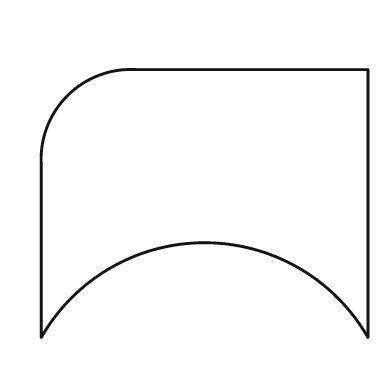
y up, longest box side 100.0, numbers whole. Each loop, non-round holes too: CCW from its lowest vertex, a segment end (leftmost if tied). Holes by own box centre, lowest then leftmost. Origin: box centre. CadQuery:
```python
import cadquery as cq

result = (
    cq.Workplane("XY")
    .moveTo(-50.0, -41.0)
    .threePointArc((0.0, -12.0), (50.0, -41.0))
    .lineTo(50.0, 41.0)
    .lineTo(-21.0, 41.0)
    .threePointArc((-42.0, 33.0), (-50.0, 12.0))
    .close()
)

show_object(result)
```